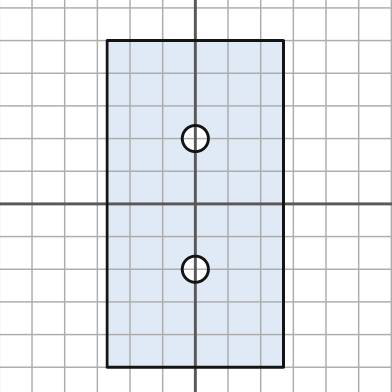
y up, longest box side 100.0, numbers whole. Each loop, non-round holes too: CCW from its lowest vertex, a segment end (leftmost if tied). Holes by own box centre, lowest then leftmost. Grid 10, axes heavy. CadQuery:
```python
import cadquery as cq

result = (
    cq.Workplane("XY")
    .moveTo(-27.0, -50.0)
    .lineTo(27.0, -50.0)
    .lineTo(27.0, 50.0)
    .lineTo(-27.0, 50.0)
    .close()
    .moveTo(0.0, -20.0)
    .circle(4.0)
    .moveTo(0.0, 20.0)
    .circle(4.0)
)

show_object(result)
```